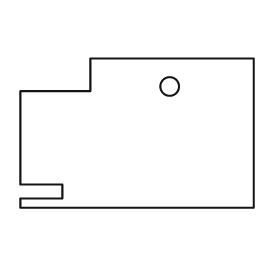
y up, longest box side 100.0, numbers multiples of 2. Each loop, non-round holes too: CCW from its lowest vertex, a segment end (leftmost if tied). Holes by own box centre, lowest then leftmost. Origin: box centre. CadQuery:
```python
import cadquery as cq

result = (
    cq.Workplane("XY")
    .moveTo(-50.0, -32.0)
    .lineTo(50.0, -32.0)
    .lineTo(50.0, 32.0)
    .lineTo(-20.0, 32.0)
    .lineTo(-20.0, 18.0)
    .lineTo(-50.0, 18.0)
    .lineTo(-50.0, -22.0)
    .lineTo(-32.0, -22.0)
    .lineTo(-32.0, -28.0)
    .lineTo(-50.0, -28.0)
    .close()
    .moveTo(14.0, 20.0)
    .circle(4.0)
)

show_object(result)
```